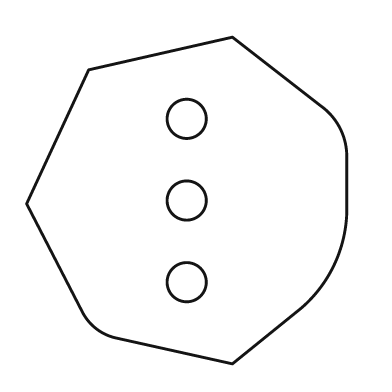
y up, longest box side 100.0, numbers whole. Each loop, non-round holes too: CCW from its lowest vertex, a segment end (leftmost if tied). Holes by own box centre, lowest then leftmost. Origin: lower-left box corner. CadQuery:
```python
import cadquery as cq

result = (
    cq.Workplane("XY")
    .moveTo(63.0, 0.0)
    .lineTo(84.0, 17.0)
    .threePointArc((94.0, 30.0), (98.0, 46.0))
    .lineTo(98.0, 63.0)
    .threePointArc((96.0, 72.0), (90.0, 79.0))
    .lineTo(63.0, 100.0)
    .lineTo(19.0, 90.0)
    .lineTo(0.0, 49.0)
    .lineTo(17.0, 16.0)
    .threePointArc((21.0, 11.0), (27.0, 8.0))
    .close()
    .moveTo(49.0, 25.0)
    .circle(6.0)
    .moveTo(49.0, 50.0)
    .circle(6.0)
    .moveTo(49.0, 75.0)
    .circle(6.0)
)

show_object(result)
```